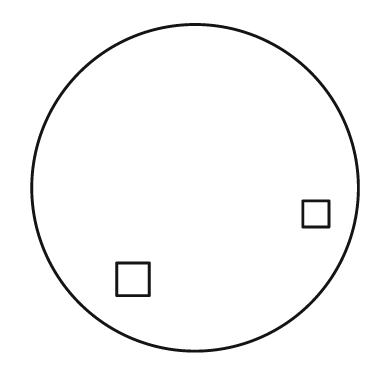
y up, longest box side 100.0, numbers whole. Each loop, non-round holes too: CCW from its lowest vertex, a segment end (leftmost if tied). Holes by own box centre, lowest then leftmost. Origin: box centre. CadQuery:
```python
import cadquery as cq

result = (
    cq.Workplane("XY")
    .moveTo(0.0, 0.0)
    .circle(50.0)
    .moveTo(-24.0, -33.0)
    .lineTo(-14.0, -33.0)
    .lineTo(-14.0, -23.0)
    .lineTo(-24.0, -23.0)
    .close()
    .moveTo(33.0, -12.0)
    .lineTo(41.0, -12.0)
    .lineTo(41.0, -4.0)
    .lineTo(33.0, -4.0)
    .close()
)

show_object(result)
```